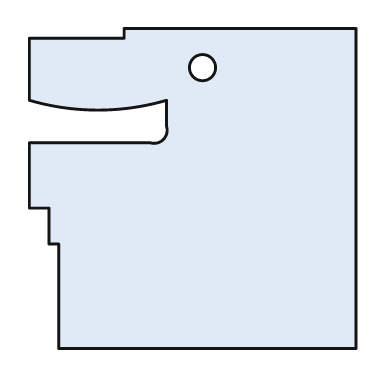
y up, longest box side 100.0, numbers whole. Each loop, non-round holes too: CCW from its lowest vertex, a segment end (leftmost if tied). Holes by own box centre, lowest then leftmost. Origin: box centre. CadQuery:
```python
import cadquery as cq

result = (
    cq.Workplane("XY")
    .moveTo(-41.0, -49.0)
    .lineTo(50.0, -49.0)
    .lineTo(50.0, 49.0)
    .lineTo(-21.0, 49.0)
    .lineTo(-21.0, 46.0)
    .lineTo(-50.0, 46.0)
    .lineTo(-50.0, 27.0)
    .threePointArc((-29.0, 24.0), (-8.0, 27.0))
    .lineTo(-8.0, 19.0)
    .threePointArc((-9.0, 15.0), (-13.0, 14.0))
    .lineTo(-50.0, 14.0)
    .lineTo(-50.0, -6.0)
    .lineTo(-44.0, -6.0)
    .lineTo(-44.0, -17.0)
    .lineTo(-41.0, -17.0)
    .close()
    .moveTo(3.0, 37.0)
    .circle(4.0)
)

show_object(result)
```